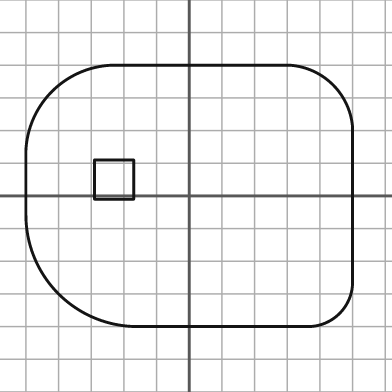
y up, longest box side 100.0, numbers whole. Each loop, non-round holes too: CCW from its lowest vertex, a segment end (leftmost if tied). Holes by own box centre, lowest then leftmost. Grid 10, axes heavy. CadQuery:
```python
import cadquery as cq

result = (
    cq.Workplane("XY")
    .moveTo(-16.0, -40.0)
    .lineTo(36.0, -40.0)
    .threePointArc((46.0, -36.0), (50.0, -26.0))
    .lineTo(50.0, 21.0)
    .threePointArc((44.0, 34.0), (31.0, 40.0))
    .lineTo(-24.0, 40.0)
    .threePointArc((-42.0, 32.0), (-50.0, 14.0))
    .lineTo(-50.0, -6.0)
    .threePointArc((-40.0, -30.0), (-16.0, -40.0))
    .close()
    .moveTo(-29.0, -1.0)
    .lineTo(-17.0, -1.0)
    .lineTo(-17.0, 11.0)
    .lineTo(-29.0, 11.0)
    .close()
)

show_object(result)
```